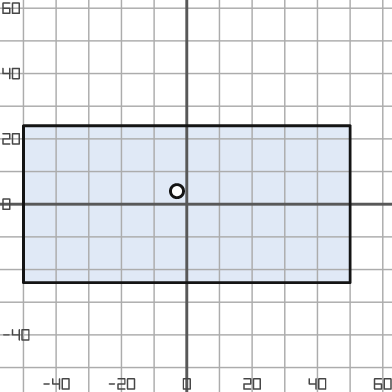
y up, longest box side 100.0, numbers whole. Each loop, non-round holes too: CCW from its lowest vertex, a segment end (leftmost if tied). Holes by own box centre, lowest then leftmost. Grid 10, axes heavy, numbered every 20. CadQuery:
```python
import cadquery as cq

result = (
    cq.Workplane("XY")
    .moveTo(-50.0, -24.0)
    .lineTo(50.0, -24.0)
    .lineTo(50.0, 24.0)
    .lineTo(-50.0, 24.0)
    .close()
    .moveTo(-3.0, 4.0)
    .circle(2.0)
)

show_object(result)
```